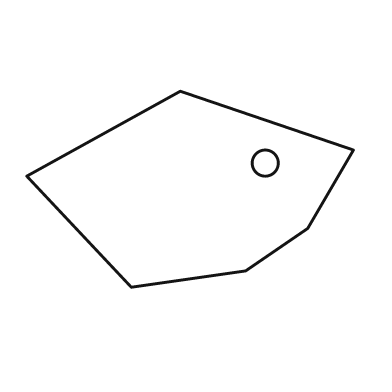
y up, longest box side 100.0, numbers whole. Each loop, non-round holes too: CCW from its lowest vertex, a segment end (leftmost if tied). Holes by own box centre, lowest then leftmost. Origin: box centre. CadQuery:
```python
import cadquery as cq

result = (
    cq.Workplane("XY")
    .moveTo(-18.0, -30.0)
    .lineTo(17.0, -25.0)
    .lineTo(36.0, -12.0)
    .lineTo(50.0, 12.0)
    .lineTo(-3.0, 30.0)
    .lineTo(-50.0, 4.0)
    .close()
    .moveTo(23.0, 8.0)
    .circle(4.0)
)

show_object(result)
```